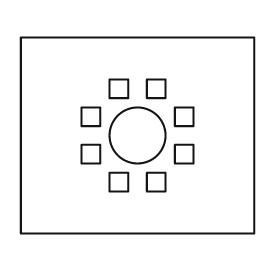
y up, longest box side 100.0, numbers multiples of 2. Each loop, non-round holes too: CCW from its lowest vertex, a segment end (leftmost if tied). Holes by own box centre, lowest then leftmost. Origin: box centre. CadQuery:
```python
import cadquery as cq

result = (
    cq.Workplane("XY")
    .moveTo(-50.0, -42.0)
    .lineTo(50.0, -42.0)
    .lineTo(50.0, 42.0)
    .lineTo(-50.0, 42.0)
    .close()
    .moveTo(-12.0, -24.0)
    .lineTo(-4.0, -24.0)
    .lineTo(-4.0, -16.0)
    .lineTo(-12.0, -16.0)
    .close()
    .moveTo(4.0, -24.0)
    .lineTo(12.0, -24.0)
    .lineTo(12.0, -16.0)
    .lineTo(4.0, -16.0)
    .close()
    .moveTo(-24.0, -12.0)
    .lineTo(-16.0, -12.0)
    .lineTo(-16.0, -4.0)
    .lineTo(-24.0, -4.0)
    .close()
    .moveTo(16.0, -12.0)
    .lineTo(24.0, -12.0)
    .lineTo(24.0, -4.0)
    .lineTo(16.0, -4.0)
    .close()
    .moveTo(0.0, 0.0)
    .circle(12.0)
    .moveTo(-24.0, 4.0)
    .lineTo(-16.0, 4.0)
    .lineTo(-16.0, 12.0)
    .lineTo(-24.0, 12.0)
    .close()
    .moveTo(16.0, 4.0)
    .lineTo(24.0, 4.0)
    .lineTo(24.0, 12.0)
    .lineTo(16.0, 12.0)
    .close()
    .moveTo(-12.0, 16.0)
    .lineTo(-4.0, 16.0)
    .lineTo(-4.0, 24.0)
    .lineTo(-12.0, 24.0)
    .close()
    .moveTo(4.0, 16.0)
    .lineTo(12.0, 16.0)
    .lineTo(12.0, 24.0)
    .lineTo(4.0, 24.0)
    .close()
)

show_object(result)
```